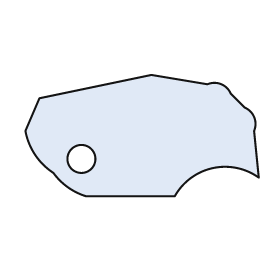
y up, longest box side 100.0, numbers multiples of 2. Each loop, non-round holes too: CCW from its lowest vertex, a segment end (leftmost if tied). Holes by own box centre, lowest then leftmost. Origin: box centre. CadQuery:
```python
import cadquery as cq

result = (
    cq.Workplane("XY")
    .moveTo(-24.0, -26.0)
    .lineTo(14.0, -26.0)
    .threePointArc((30.0, -14.0), (50.0, -18.0))
    .lineTo(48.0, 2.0)
    .threePointArc((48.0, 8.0), (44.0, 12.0))
    .lineTo(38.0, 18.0)
    .threePointArc((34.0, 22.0), (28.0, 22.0))
    .lineTo(4.0, 26.0)
    .lineTo(-44.0, 16.0)
    .lineTo(-50.0, 2.0)
    .threePointArc((-46.0, -8.0), (-38.0, -16.0))
    .threePointArc((-32.0, -22.0), (-24.0, -26.0))
    .close()
    .moveTo(-26.0, -10.0)
    .circle(6.0)
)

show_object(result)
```